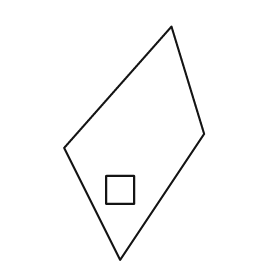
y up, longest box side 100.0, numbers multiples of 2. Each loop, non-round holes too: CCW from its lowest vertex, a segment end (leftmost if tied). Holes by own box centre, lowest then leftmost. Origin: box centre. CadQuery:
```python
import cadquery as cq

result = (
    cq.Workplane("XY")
    .moveTo(-6.0, -50.0)
    .lineTo(30.0, 4.0)
    .lineTo(16.0, 50.0)
    .lineTo(-30.0, -2.0)
    .close()
    .moveTo(-12.0, -26.0)
    .lineTo(0.0, -26.0)
    .lineTo(0.0, -14.0)
    .lineTo(-12.0, -14.0)
    .close()
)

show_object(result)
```